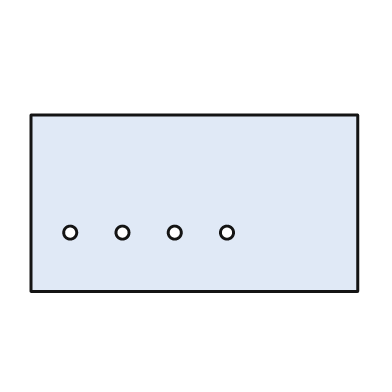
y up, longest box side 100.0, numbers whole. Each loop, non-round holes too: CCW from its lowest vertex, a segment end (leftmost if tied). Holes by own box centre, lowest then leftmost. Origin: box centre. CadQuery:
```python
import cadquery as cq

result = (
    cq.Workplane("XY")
    .moveTo(-50.0, -27.0)
    .lineTo(50.0, -27.0)
    .lineTo(50.0, 27.0)
    .lineTo(-50.0, 27.0)
    .close()
    .moveTo(-38.0, -9.0)
    .circle(2.0)
    .moveTo(-22.0, -9.0)
    .circle(2.0)
    .moveTo(-6.0, -9.0)
    .circle(2.0)
    .moveTo(10.0, -9.0)
    .circle(2.0)
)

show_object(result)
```